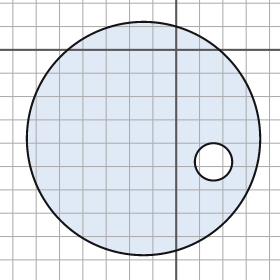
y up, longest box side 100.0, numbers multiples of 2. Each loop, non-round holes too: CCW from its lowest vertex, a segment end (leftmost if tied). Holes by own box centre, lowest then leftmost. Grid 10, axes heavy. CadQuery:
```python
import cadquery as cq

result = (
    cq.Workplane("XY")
    .moveTo(-14.0, -38.0)
    .circle(50.0)
    .moveTo(16.0, -48.0)
    .circle(8.0)
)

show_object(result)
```